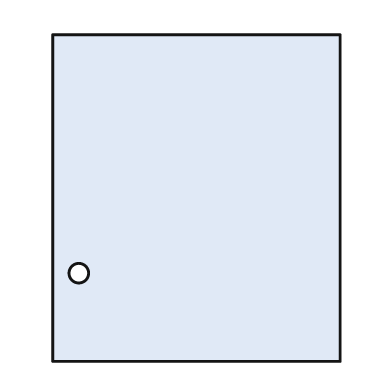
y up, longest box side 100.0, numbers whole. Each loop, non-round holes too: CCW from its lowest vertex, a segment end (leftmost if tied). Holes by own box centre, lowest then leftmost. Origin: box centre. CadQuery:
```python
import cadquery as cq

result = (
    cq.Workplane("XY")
    .moveTo(-44.0, -50.0)
    .lineTo(44.0, -50.0)
    .lineTo(44.0, 50.0)
    .lineTo(-44.0, 50.0)
    .close()
    .moveTo(-36.0, -23.0)
    .circle(3.0)
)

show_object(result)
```